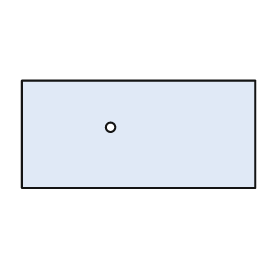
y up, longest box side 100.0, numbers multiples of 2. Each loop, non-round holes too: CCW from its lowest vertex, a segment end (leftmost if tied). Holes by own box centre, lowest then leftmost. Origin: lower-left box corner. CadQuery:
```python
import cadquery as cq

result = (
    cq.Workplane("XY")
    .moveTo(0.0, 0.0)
    .lineTo(100.0, 0.0)
    .lineTo(100.0, 46.0)
    .lineTo(0.0, 46.0)
    .close()
    .moveTo(38.0, 26.0)
    .circle(2.0)
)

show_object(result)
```